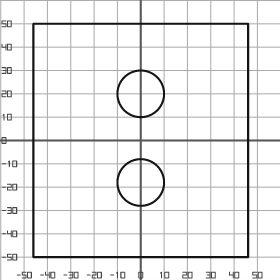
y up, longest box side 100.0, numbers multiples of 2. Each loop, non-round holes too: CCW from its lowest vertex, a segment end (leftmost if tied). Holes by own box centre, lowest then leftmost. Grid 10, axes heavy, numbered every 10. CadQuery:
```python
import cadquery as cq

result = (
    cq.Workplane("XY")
    .moveTo(-46.0, -50.0)
    .lineTo(46.0, -50.0)
    .lineTo(46.0, 50.0)
    .lineTo(-46.0, 50.0)
    .close()
    .moveTo(0.0, -18.0)
    .circle(10.0)
    .moveTo(0.0, 20.0)
    .circle(10.0)
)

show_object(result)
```